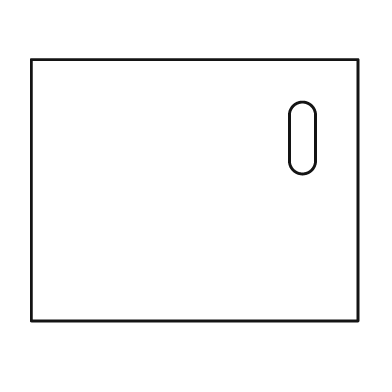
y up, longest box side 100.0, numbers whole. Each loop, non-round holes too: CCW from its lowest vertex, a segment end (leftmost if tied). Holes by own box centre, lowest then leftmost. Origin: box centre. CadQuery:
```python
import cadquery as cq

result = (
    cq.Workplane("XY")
    .moveTo(-50.0, -40.0)
    .lineTo(50.0, -40.0)
    .lineTo(50.0, 40.0)
    .lineTo(-50.0, 40.0)
    .close()
    .moveTo(29.0, 9.0)
    .threePointArc((33.0, 5.0), (37.0, 9.0))
    .lineTo(37.0, 23.0)
    .threePointArc((33.0, 27.0), (29.0, 23.0))
    .close()
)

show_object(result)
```